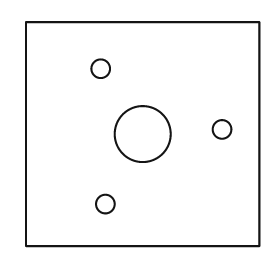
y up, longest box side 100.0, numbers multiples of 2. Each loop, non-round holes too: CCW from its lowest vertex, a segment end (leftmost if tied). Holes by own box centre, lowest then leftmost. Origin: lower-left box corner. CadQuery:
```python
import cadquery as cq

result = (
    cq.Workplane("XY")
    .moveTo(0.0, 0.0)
    .lineTo(100.0, 0.0)
    .lineTo(100.0, 96.0)
    .lineTo(0.0, 96.0)
    .close()
    .moveTo(34.0, 18.0)
    .circle(4.0)
    .moveTo(50.0, 48.0)
    .circle(12.0)
    .moveTo(84.0, 50.0)
    .circle(4.0)
    .moveTo(32.0, 76.0)
    .circle(4.0)
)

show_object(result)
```